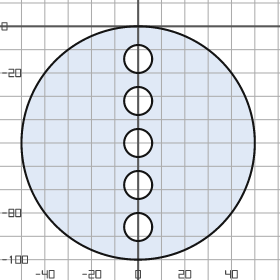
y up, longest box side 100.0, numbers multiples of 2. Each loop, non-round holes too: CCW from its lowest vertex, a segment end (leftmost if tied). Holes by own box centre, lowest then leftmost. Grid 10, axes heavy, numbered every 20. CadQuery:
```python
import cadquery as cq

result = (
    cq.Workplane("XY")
    .moveTo(0.0, -50.0)
    .circle(50.0)
    .moveTo(0.0, -86.0)
    .circle(6.0)
    .moveTo(0.0, -68.0)
    .circle(6.0)
    .moveTo(0.0, -50.0)
    .circle(6.0)
    .moveTo(0.0, -32.0)
    .circle(6.0)
    .moveTo(0.0, -14.0)
    .circle(6.0)
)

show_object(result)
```